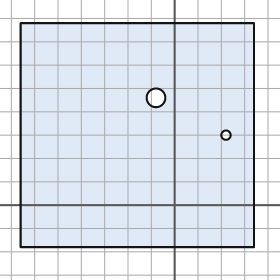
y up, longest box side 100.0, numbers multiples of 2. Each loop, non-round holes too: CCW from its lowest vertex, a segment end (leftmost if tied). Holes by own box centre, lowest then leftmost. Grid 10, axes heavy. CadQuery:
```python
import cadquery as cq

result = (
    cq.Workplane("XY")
    .moveTo(-66.0, -18.0)
    .lineTo(34.0, -18.0)
    .lineTo(34.0, 78.0)
    .lineTo(-66.0, 78.0)
    .close()
    .moveTo(22.0, 30.0)
    .circle(2.0)
    .moveTo(-8.0, 46.0)
    .circle(4.0)
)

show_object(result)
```